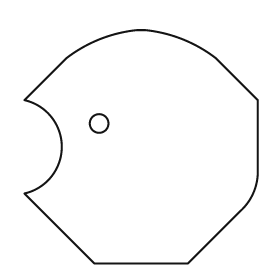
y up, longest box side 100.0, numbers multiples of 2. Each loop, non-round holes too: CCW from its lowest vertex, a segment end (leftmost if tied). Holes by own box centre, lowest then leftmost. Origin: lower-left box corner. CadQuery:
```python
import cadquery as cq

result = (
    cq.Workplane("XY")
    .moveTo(30.0, 0.0)
    .lineTo(70.0, 0.0)
    .lineTo(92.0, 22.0)
    .threePointArc((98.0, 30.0), (100.0, 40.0))
    .lineTo(100.0, 70.0)
    .lineTo(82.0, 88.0)
    .threePointArc((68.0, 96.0), (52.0, 100.0))
    .lineTo(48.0, 100.0)
    .threePointArc((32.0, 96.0), (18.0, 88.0))
    .lineTo(0.0, 70.0)
    .threePointArc((16.0, 50.0), (0.0, 30.0))
    .close()
    .moveTo(32.0, 60.0)
    .circle(4.0)
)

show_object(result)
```